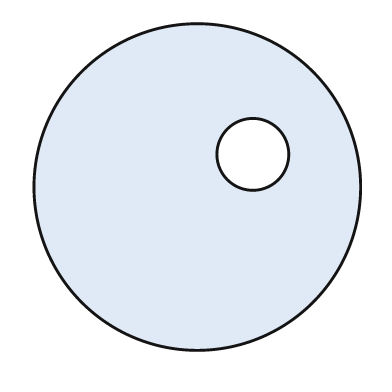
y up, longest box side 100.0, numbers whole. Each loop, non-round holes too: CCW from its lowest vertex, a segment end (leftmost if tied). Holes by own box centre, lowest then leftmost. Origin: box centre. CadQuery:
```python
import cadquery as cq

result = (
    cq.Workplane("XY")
    .moveTo(0.0, 0.0)
    .circle(50.0)
    .moveTo(17.0, 10.0)
    .circle(11.0)
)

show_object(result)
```